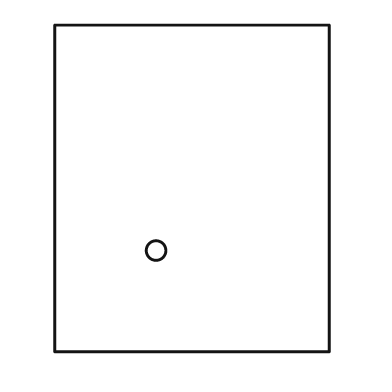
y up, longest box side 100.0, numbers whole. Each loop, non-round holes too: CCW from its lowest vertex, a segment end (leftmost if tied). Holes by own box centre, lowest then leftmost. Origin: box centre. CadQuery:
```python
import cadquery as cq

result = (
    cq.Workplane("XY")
    .moveTo(-42.0, -50.0)
    .lineTo(42.0, -50.0)
    .lineTo(42.0, 50.0)
    .lineTo(-42.0, 50.0)
    .close()
    .moveTo(-11.0, -19.0)
    .circle(3.0)
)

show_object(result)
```